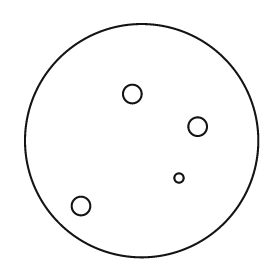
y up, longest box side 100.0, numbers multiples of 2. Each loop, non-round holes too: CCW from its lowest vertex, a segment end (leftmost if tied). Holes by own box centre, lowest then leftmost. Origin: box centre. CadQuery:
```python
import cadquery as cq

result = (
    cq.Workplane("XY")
    .moveTo(0.0, 0.0)
    .circle(50.0)
    .moveTo(-26.0, -28.0)
    .circle(4.0)
    .moveTo(16.0, -16.0)
    .circle(2.0)
    .moveTo(24.0, 6.0)
    .circle(4.0)
    .moveTo(-4.0, 20.0)
    .circle(4.0)
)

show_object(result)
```